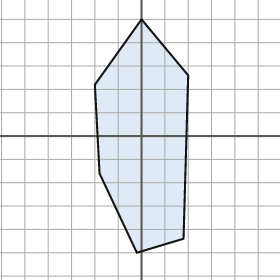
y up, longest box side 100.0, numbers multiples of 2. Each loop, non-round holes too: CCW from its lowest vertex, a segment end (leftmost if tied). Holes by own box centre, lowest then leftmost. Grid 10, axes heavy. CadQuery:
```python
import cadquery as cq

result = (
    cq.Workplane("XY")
    .moveTo(-2.0, -50.0)
    .lineTo(18.0, -44.0)
    .lineTo(20.0, 26.0)
    .lineTo(0.0, 50.0)
    .lineTo(-20.0, 22.0)
    .lineTo(-18.0, -16.0)
    .close()
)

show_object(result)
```